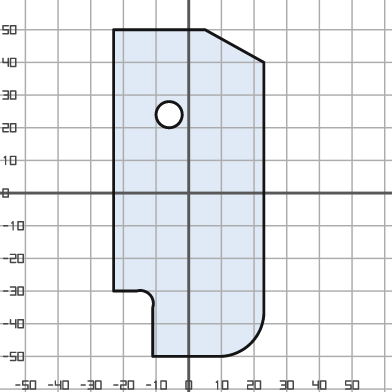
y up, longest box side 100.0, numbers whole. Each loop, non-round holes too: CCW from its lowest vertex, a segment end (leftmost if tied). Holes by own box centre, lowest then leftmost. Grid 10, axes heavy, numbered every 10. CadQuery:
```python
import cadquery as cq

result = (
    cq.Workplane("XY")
    .moveTo(-11.0, -50.0)
    .lineTo(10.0, -50.0)
    .threePointArc((19.0, -46.0), (23.0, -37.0))
    .lineTo(23.0, 40.0)
    .lineTo(5.0, 50.0)
    .lineTo(-23.0, 50.0)
    .lineTo(-23.0, -30.0)
    .lineTo(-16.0, -30.0)
    .threePointArc((-12.0, -31.0), (-11.0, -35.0))
    .close()
    .moveTo(-6.0, 24.0)
    .circle(4.0)
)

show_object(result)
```